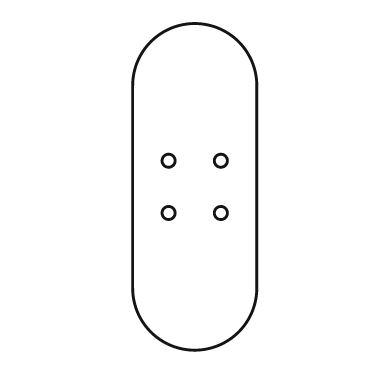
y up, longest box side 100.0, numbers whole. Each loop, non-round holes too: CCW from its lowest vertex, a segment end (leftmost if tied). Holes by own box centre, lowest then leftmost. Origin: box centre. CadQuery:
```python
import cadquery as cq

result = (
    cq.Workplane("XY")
    .moveTo(-19.0, -31.0)
    .threePointArc((0.0, -50.0), (19.0, -31.0))
    .lineTo(19.0, 31.0)
    .threePointArc((0.0, 50.0), (-19.0, 31.0))
    .close()
    .moveTo(-8.0, -8.0)
    .circle(2.0)
    .moveTo(8.0, -8.0)
    .circle(2.0)
    .moveTo(-8.0, 8.0)
    .circle(2.0)
    .moveTo(8.0, 8.0)
    .circle(2.0)
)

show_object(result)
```